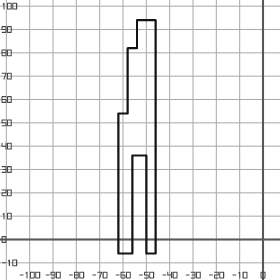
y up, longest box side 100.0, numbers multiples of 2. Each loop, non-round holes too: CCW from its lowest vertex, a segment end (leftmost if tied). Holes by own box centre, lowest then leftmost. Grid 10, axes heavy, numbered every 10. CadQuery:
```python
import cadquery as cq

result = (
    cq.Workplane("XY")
    .moveTo(-62.0, -6.0)
    .lineTo(-56.0, -6.0)
    .lineTo(-56.0, 36.0)
    .lineTo(-50.0, 36.0)
    .lineTo(-50.0, -6.0)
    .lineTo(-46.0, -6.0)
    .lineTo(-46.0, 94.0)
    .lineTo(-54.0, 94.0)
    .lineTo(-54.0, 82.0)
    .lineTo(-58.0, 82.0)
    .lineTo(-58.0, 54.0)
    .lineTo(-62.0, 54.0)
    .close()
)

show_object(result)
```